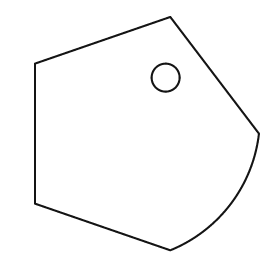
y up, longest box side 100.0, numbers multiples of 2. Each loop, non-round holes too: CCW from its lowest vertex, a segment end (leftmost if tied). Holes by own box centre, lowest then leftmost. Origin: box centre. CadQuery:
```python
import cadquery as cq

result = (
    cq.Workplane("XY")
    .moveTo(10.0, -50.0)
    .threePointArc((36.0, -30.0), (48.0, 0.0))
    .lineTo(10.0, 50.0)
    .lineTo(-48.0, 30.0)
    .lineTo(-48.0, -30.0)
    .close()
    .moveTo(8.0, 24.0)
    .circle(6.0)
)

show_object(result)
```